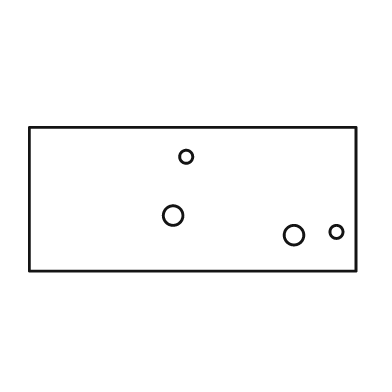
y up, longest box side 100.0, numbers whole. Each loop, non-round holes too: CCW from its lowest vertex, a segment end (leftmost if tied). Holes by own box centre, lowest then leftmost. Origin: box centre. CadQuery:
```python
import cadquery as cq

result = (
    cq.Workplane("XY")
    .moveTo(-50.0, -22.0)
    .lineTo(50.0, -22.0)
    .lineTo(50.0, 22.0)
    .lineTo(-50.0, 22.0)
    .close()
    .moveTo(31.0, -11.0)
    .circle(3.0)
    .moveTo(44.0, -10.0)
    .circle(2.0)
    .moveTo(-6.0, -5.0)
    .circle(3.0)
    .moveTo(-2.0, 13.0)
    .circle(2.0)
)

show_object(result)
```